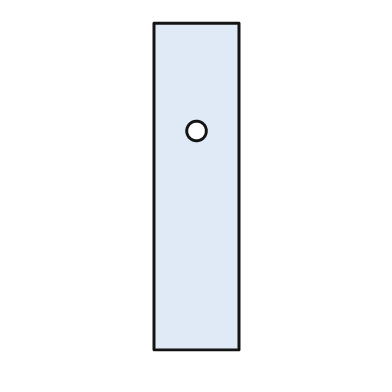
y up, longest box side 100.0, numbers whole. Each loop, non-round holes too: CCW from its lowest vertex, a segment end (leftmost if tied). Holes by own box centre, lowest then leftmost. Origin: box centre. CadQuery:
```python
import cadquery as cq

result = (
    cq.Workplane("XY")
    .moveTo(-13.0, -50.0)
    .lineTo(13.0, -50.0)
    .lineTo(13.0, 50.0)
    .lineTo(-13.0, 50.0)
    .close()
    .moveTo(0.0, 17.0)
    .circle(3.0)
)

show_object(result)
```